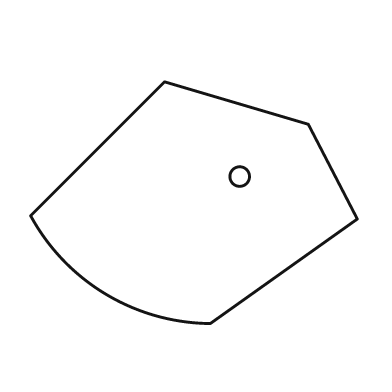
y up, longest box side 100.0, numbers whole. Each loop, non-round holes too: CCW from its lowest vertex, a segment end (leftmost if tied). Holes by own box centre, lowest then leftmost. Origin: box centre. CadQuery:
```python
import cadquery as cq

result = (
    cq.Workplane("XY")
    .moveTo(5.0, -37.0)
    .lineTo(50.0, -5.0)
    .lineTo(35.0, 24.0)
    .lineTo(-9.0, 37.0)
    .lineTo(-50.0, -4.0)
    .threePointArc((-27.0, -28.0), (5.0, -37.0))
    .close()
    .moveTo(14.0, 8.0)
    .circle(3.0)
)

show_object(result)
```